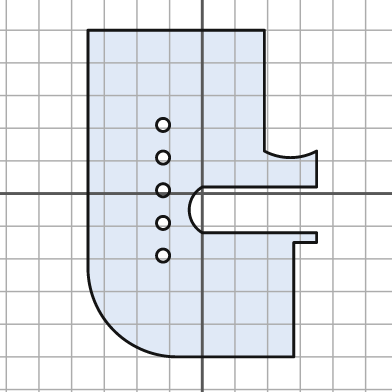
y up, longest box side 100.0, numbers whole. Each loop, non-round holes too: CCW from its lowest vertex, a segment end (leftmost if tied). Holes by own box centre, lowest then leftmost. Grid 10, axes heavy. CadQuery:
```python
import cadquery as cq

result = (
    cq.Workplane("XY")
    .moveTo(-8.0, -50.0)
    .lineTo(28.0, -50.0)
    .lineTo(28.0, -15.0)
    .lineTo(35.0, -15.0)
    .lineTo(35.0, -12.0)
    .lineTo(0.0, -12.0)
    .threePointArc((-4.0, -5.0), (0.0, 2.0))
    .lineTo(35.0, 2.0)
    .lineTo(35.0, 13.0)
    .threePointArc((27.0, 11.0), (19.0, 13.0))
    .lineTo(19.0, 50.0)
    .lineTo(-35.0, 50.0)
    .lineTo(-35.0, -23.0)
    .threePointArc((-27.0, -42.0), (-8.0, -50.0))
    .close()
    .moveTo(-12.0, -19.0)
    .circle(2.0)
    .moveTo(-12.0, -9.0)
    .circle(2.0)
    .moveTo(-12.0, 1.0)
    .circle(2.0)
    .moveTo(-12.0, 11.0)
    .circle(2.0)
    .moveTo(-12.0, 21.0)
    .circle(2.0)
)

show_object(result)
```